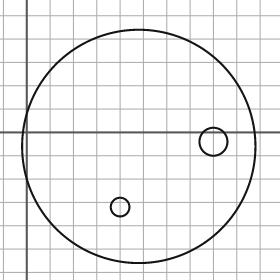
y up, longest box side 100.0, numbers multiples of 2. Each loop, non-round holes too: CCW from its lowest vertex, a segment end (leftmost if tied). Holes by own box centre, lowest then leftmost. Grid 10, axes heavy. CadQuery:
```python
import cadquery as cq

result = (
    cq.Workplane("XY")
    .moveTo(48.0, -6.0)
    .circle(50.0)
    .moveTo(40.0, -32.0)
    .circle(4.0)
    .moveTo(80.0, -4.0)
    .circle(6.0)
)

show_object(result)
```